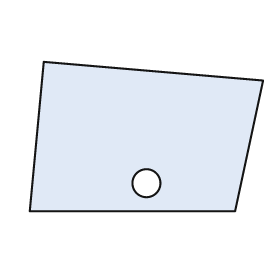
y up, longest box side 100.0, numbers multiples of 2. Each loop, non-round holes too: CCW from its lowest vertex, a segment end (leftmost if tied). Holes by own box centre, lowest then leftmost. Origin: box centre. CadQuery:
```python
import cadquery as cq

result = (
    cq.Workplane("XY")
    .moveTo(-50.0, -32.0)
    .lineTo(38.0, -32.0)
    .lineTo(50.0, 24.0)
    .lineTo(-44.0, 32.0)
    .close()
    .moveTo(0.0, -20.0)
    .circle(6.0)
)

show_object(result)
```